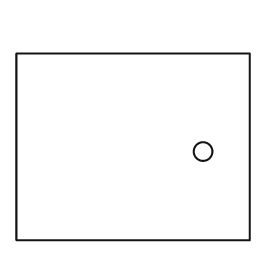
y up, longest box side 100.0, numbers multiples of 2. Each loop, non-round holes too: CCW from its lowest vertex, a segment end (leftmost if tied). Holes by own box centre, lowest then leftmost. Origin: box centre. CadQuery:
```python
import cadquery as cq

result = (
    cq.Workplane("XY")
    .moveTo(-50.0, -40.0)
    .lineTo(50.0, -40.0)
    .lineTo(50.0, 40.0)
    .lineTo(-50.0, 40.0)
    .close()
    .moveTo(30.0, -2.0)
    .circle(4.0)
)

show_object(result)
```